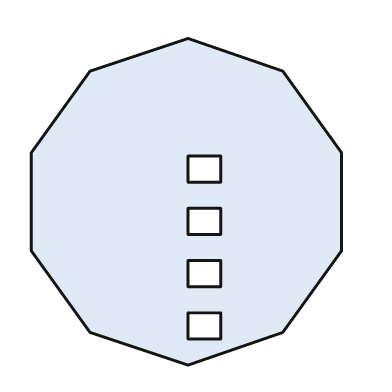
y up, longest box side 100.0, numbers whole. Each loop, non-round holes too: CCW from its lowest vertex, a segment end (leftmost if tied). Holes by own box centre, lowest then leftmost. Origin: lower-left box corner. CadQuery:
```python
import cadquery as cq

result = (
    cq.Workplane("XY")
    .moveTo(48.0, 0.0)
    .lineTo(77.0, 10.0)
    .lineTo(95.0, 35.0)
    .lineTo(95.0, 65.0)
    .lineTo(77.0, 90.0)
    .lineTo(48.0, 100.0)
    .lineTo(18.0, 90.0)
    .lineTo(0.0, 65.0)
    .lineTo(0.0, 35.0)
    .lineTo(18.0, 10.0)
    .close()
    .moveTo(48.0, 8.0)
    .lineTo(58.0, 8.0)
    .lineTo(58.0, 16.0)
    .lineTo(48.0, 16.0)
    .close()
    .moveTo(48.0, 24.0)
    .lineTo(58.0, 24.0)
    .lineTo(58.0, 32.0)
    .lineTo(48.0, 32.0)
    .close()
    .moveTo(48.0, 40.0)
    .lineTo(58.0, 40.0)
    .lineTo(58.0, 48.0)
    .lineTo(48.0, 48.0)
    .close()
    .moveTo(48.0, 56.0)
    .lineTo(58.0, 56.0)
    .lineTo(58.0, 64.0)
    .lineTo(48.0, 64.0)
    .close()
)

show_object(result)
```